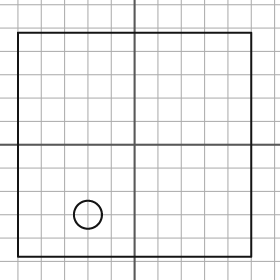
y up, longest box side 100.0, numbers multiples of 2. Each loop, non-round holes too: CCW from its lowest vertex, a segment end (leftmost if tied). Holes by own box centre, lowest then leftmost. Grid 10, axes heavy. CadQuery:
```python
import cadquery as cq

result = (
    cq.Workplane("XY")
    .moveTo(-50.0, -48.0)
    .lineTo(50.0, -48.0)
    .lineTo(50.0, 48.0)
    .lineTo(-50.0, 48.0)
    .close()
    .moveTo(-20.0, -30.0)
    .circle(6.0)
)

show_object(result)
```